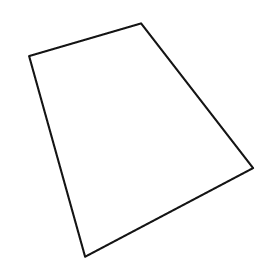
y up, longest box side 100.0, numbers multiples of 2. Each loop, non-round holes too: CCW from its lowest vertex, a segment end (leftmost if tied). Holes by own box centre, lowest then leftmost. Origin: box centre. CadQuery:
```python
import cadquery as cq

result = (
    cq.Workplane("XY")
    .moveTo(-24.0, -50.0)
    .lineTo(48.0, -12.0)
    .lineTo(0.0, 50.0)
    .lineTo(-48.0, 36.0)
    .close()
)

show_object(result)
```